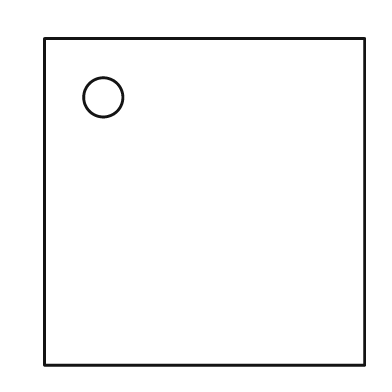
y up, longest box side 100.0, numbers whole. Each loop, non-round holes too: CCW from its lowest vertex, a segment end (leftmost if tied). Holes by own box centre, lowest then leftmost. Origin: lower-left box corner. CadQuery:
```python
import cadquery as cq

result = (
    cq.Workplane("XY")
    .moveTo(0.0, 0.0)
    .lineTo(98.0, 0.0)
    .lineTo(98.0, 100.0)
    .lineTo(0.0, 100.0)
    .close()
    .moveTo(18.0, 82.0)
    .circle(6.0)
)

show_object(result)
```